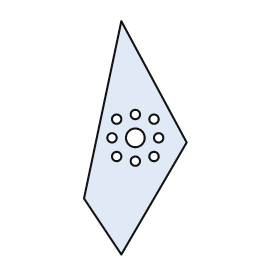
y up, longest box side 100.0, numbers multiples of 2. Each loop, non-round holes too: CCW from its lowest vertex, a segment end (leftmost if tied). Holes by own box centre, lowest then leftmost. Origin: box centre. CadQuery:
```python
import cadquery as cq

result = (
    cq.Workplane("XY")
    .moveTo(-6.0, -50.0)
    .lineTo(22.0, -2.0)
    .lineTo(-6.0, 50.0)
    .lineTo(-22.0, -26.0)
    .close()
    .moveTo(0.0, -10.0)
    .circle(2.0)
    .moveTo(-8.0, -8.0)
    .circle(2.0)
    .moveTo(8.0, -8.0)
    .circle(2.0)
    .moveTo(-10.0, 0.0)
    .circle(2.0)
    .moveTo(0.0, 0.0)
    .circle(4.0)
    .moveTo(10.0, 0.0)
    .circle(2.0)
    .moveTo(-8.0, 8.0)
    .circle(2.0)
    .moveTo(8.0, 8.0)
    .circle(2.0)
    .moveTo(0.0, 10.0)
    .circle(2.0)
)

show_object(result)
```